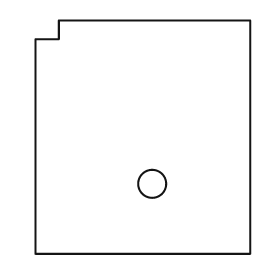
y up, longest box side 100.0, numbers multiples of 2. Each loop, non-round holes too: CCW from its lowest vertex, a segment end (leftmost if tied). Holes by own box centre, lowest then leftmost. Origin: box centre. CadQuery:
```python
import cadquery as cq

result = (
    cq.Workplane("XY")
    .moveTo(-46.0, -50.0)
    .lineTo(46.0, -50.0)
    .lineTo(46.0, 50.0)
    .lineTo(-36.0, 50.0)
    .lineTo(-36.0, 42.0)
    .lineTo(-46.0, 42.0)
    .close()
    .moveTo(4.0, -20.0)
    .circle(6.0)
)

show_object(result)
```